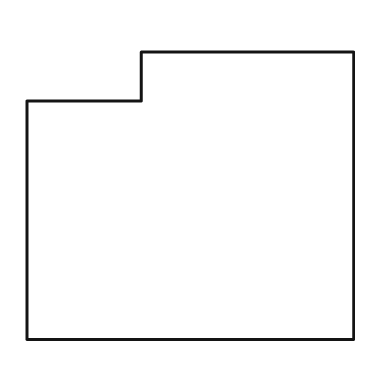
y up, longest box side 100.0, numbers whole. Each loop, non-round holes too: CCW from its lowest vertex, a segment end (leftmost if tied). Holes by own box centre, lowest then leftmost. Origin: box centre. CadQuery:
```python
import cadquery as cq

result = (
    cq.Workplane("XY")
    .moveTo(-50.0, -44.0)
    .lineTo(50.0, -44.0)
    .lineTo(50.0, 44.0)
    .lineTo(-15.0, 44.0)
    .lineTo(-15.0, 29.0)
    .lineTo(-50.0, 29.0)
    .close()
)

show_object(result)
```